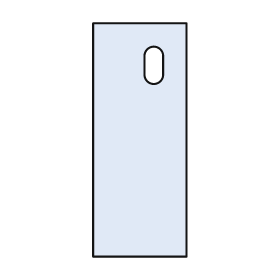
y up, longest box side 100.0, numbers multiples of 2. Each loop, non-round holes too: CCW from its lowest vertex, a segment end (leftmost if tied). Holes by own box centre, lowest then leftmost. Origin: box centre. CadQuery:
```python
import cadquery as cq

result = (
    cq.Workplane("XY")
    .moveTo(-20.0, -50.0)
    .lineTo(20.0, -50.0)
    .lineTo(20.0, 50.0)
    .lineTo(-20.0, 50.0)
    .close()
    .moveTo(2.0, 28.0)
    .threePointArc((6.0, 24.0), (10.0, 28.0))
    .lineTo(10.0, 36.0)
    .threePointArc((6.0, 40.0), (2.0, 36.0))
    .close()
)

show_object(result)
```